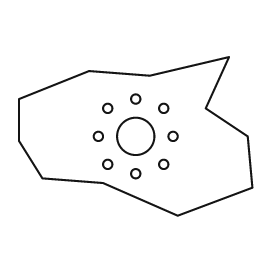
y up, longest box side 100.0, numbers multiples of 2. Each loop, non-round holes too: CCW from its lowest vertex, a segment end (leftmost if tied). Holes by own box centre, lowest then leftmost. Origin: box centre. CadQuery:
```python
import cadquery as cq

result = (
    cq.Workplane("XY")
    .moveTo(18.0, -34.0)
    .lineTo(50.0, -22.0)
    .lineTo(48.0, 0.0)
    .lineTo(30.0, 12.0)
    .lineTo(40.0, 34.0)
    .lineTo(6.0, 26.0)
    .lineTo(-20.0, 28.0)
    .lineTo(-50.0, 16.0)
    .lineTo(-50.0, -2.0)
    .lineTo(-40.0, -18.0)
    .lineTo(-14.0, -20.0)
    .close()
    .moveTo(0.0, -16.0)
    .circle(2.0)
    .moveTo(-12.0, -12.0)
    .circle(2.0)
    .moveTo(12.0, -12.0)
    .circle(2.0)
    .moveTo(-16.0, 0.0)
    .circle(2.0)
    .moveTo(0.0, 0.0)
    .circle(8.0)
    .moveTo(16.0, 0.0)
    .circle(2.0)
    .moveTo(-12.0, 12.0)
    .circle(2.0)
    .moveTo(12.0, 12.0)
    .circle(2.0)
    .moveTo(0.0, 16.0)
    .circle(2.0)
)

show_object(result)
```